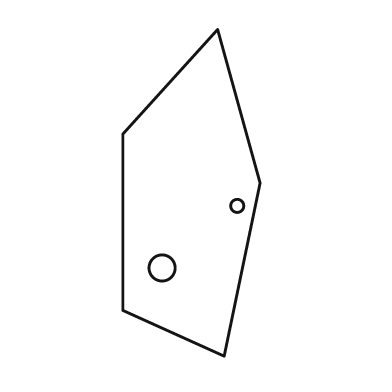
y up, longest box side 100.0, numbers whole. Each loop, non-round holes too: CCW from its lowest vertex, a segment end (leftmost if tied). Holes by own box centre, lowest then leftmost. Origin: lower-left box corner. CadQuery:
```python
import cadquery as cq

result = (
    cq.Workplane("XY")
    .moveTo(31.0, 0.0)
    .lineTo(42.0, 53.0)
    .lineTo(29.0, 100.0)
    .lineTo(0.0, 68.0)
    .lineTo(0.0, 14.0)
    .close()
    .moveTo(12.0, 27.0)
    .circle(4.0)
    .moveTo(35.0, 46.0)
    .circle(2.0)
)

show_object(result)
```